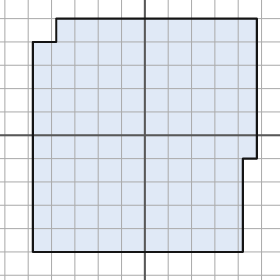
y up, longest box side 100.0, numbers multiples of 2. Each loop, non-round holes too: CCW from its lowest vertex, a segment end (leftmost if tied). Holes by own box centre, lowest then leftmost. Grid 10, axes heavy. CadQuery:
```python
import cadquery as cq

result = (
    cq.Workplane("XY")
    .moveTo(-48.0, -50.0)
    .lineTo(42.0, -50.0)
    .lineTo(42.0, -10.0)
    .lineTo(48.0, -10.0)
    .lineTo(48.0, 50.0)
    .lineTo(-38.0, 50.0)
    .lineTo(-38.0, 40.0)
    .lineTo(-48.0, 40.0)
    .close()
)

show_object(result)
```